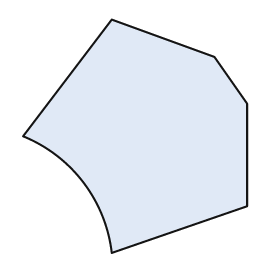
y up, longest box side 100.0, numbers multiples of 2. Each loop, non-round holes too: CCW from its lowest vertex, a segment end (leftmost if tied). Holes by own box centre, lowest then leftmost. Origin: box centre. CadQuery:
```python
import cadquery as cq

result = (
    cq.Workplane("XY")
    .moveTo(-10.0, -50.0)
    .lineTo(48.0, -30.0)
    .lineTo(48.0, 14.0)
    .lineTo(34.0, 34.0)
    .lineTo(-10.0, 50.0)
    .lineTo(-48.0, 0.0)
    .threePointArc((-22.0, -20.0), (-10.0, -50.0))
    .close()
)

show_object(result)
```